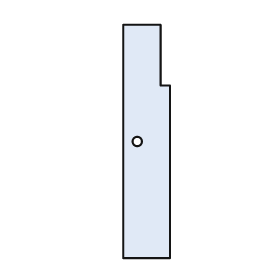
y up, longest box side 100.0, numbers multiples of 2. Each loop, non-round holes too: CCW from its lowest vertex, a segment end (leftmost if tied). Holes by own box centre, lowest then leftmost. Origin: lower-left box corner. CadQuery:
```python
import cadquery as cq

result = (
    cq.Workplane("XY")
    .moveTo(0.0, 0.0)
    .lineTo(20.0, 0.0)
    .lineTo(20.0, 74.0)
    .lineTo(16.0, 74.0)
    .lineTo(16.0, 100.0)
    .lineTo(0.0, 100.0)
    .close()
    .moveTo(6.0, 50.0)
    .circle(2.0)
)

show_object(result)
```